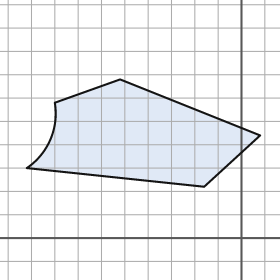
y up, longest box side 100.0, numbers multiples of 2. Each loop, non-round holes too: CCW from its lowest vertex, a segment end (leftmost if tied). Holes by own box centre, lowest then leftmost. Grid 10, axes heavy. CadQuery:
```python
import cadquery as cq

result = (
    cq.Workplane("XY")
    .moveTo(-16.0, 22.0)
    .lineTo(8.0, 44.0)
    .lineTo(-52.0, 68.0)
    .lineTo(-80.0, 58.0)
    .threePointArc((-82.0, 42.0), (-92.0, 30.0))
    .close()
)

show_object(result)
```